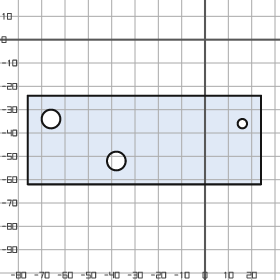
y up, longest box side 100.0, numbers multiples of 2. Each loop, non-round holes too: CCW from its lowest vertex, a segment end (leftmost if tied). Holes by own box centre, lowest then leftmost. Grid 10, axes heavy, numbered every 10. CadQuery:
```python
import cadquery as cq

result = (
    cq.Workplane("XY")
    .moveTo(-76.0, -62.0)
    .lineTo(24.0, -62.0)
    .lineTo(24.0, -24.0)
    .lineTo(-76.0, -24.0)
    .close()
    .moveTo(-38.0, -52.0)
    .circle(4.0)
    .moveTo(16.0, -36.0)
    .circle(2.0)
    .moveTo(-66.0, -34.0)
    .circle(4.0)
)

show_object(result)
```